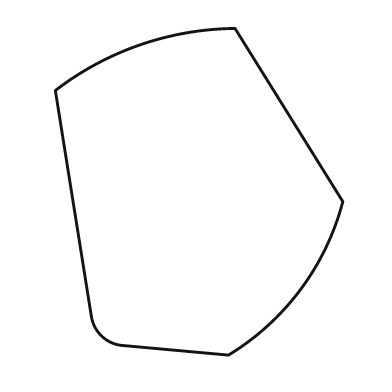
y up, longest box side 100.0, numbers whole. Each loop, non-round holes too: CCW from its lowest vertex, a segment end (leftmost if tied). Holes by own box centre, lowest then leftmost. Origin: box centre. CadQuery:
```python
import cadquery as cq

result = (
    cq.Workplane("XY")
    .moveTo(9.0, -50.0)
    .threePointArc((31.0, -30.0), (44.0, -3.0))
    .lineTo(11.0, 50.0)
    .threePointArc((-18.0, 45.0), (-44.0, 31.0))
    .lineTo(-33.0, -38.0)
    .threePointArc((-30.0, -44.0), (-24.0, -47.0))
    .close()
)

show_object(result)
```